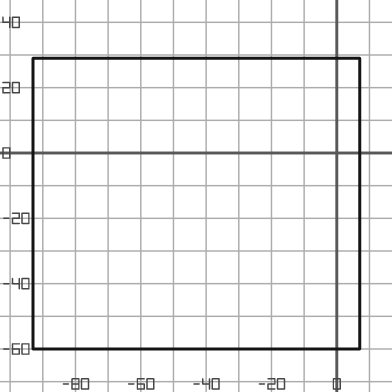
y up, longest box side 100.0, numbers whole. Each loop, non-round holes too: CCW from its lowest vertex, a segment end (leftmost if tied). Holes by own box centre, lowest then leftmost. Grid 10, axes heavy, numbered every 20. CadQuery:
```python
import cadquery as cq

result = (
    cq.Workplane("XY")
    .moveTo(-93.0, -60.0)
    .lineTo(7.0, -60.0)
    .lineTo(7.0, 29.0)
    .lineTo(-93.0, 29.0)
    .close()
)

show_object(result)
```